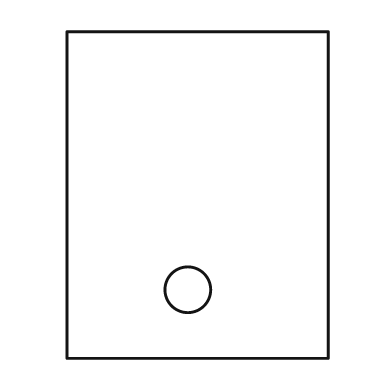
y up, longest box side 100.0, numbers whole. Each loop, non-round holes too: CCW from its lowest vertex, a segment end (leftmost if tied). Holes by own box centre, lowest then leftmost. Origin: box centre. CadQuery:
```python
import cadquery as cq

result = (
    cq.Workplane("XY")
    .moveTo(-40.0, -50.0)
    .lineTo(40.0, -50.0)
    .lineTo(40.0, 50.0)
    .lineTo(-40.0, 50.0)
    .close()
    .moveTo(-3.0, -29.0)
    .circle(7.0)
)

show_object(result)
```